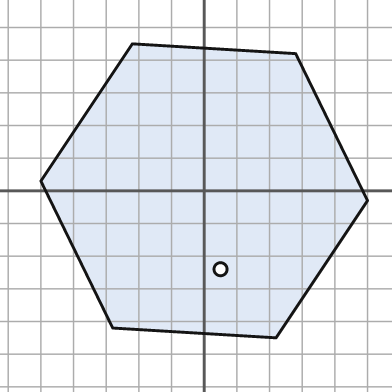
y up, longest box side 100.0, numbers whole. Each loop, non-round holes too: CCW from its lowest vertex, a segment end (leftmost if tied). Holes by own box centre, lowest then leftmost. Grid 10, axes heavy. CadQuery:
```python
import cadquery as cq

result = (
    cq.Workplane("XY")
    .moveTo(22.0, -45.0)
    .lineTo(50.0, -3.0)
    .lineTo(28.0, 42.0)
    .lineTo(-22.0, 45.0)
    .lineTo(-50.0, 3.0)
    .lineTo(-28.0, -42.0)
    .close()
    .moveTo(5.0, -24.0)
    .circle(2.0)
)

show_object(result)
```